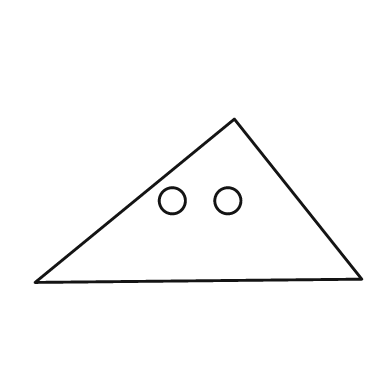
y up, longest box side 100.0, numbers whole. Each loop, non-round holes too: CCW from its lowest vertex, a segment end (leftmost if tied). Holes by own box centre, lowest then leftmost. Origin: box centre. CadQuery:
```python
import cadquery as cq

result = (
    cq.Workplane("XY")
    .moveTo(-50.0, -25.0)
    .lineTo(50.0, -24.0)
    .lineTo(11.0, 25.0)
    .close()
    .moveTo(-8.0, 0.0)
    .circle(4.0)
    .moveTo(9.0, 0.0)
    .circle(4.0)
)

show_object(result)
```